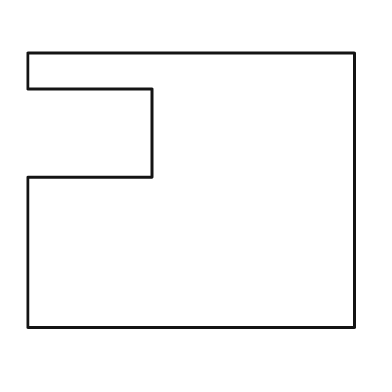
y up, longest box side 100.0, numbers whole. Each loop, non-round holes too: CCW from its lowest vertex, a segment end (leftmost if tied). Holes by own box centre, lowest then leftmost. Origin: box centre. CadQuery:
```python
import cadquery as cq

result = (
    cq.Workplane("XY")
    .moveTo(-50.0, -42.0)
    .lineTo(50.0, -42.0)
    .lineTo(50.0, 42.0)
    .lineTo(-50.0, 42.0)
    .lineTo(-50.0, 31.0)
    .lineTo(-12.0, 31.0)
    .lineTo(-12.0, 4.0)
    .lineTo(-50.0, 4.0)
    .close()
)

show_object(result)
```